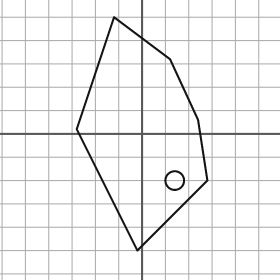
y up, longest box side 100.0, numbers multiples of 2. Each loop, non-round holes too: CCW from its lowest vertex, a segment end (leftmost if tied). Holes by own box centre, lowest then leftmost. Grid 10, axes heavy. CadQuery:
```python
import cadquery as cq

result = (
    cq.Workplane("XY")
    .moveTo(-2.0, -50.0)
    .lineTo(28.0, -20.0)
    .lineTo(24.0, 6.0)
    .lineTo(12.0, 32.0)
    .lineTo(-12.0, 50.0)
    .lineTo(-28.0, 2.0)
    .close()
    .moveTo(14.0, -20.0)
    .circle(4.0)
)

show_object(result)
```